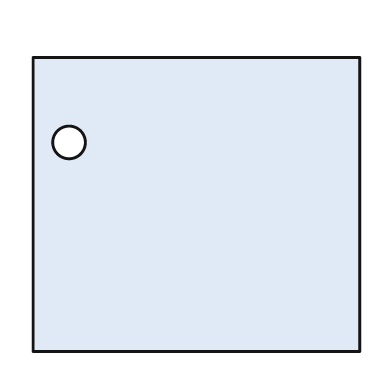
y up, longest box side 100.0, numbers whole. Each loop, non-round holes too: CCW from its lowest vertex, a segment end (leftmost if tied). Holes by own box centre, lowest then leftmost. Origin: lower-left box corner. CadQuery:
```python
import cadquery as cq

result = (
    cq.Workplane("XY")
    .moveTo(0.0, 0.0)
    .lineTo(100.0, 0.0)
    .lineTo(100.0, 90.0)
    .lineTo(0.0, 90.0)
    .close()
    .moveTo(11.0, 64.0)
    .circle(5.0)
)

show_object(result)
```